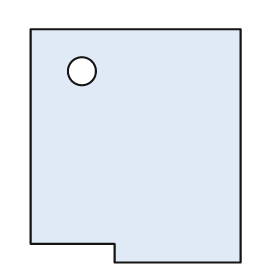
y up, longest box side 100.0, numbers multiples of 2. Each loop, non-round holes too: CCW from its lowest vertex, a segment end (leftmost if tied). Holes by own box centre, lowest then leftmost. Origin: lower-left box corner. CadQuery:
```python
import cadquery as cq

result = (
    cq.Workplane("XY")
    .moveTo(36.0, 0.0)
    .lineTo(90.0, 0.0)
    .lineTo(90.0, 100.0)
    .lineTo(0.0, 100.0)
    .lineTo(0.0, 8.0)
    .lineTo(36.0, 8.0)
    .close()
    .moveTo(22.0, 82.0)
    .circle(6.0)
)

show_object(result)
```